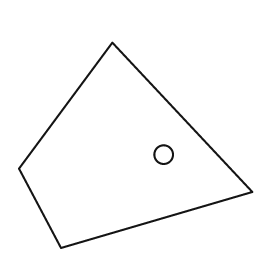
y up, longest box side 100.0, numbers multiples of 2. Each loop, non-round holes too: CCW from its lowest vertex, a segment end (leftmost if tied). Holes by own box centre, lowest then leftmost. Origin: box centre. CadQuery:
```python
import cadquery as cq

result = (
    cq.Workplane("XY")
    .moveTo(-32.0, -44.0)
    .lineTo(50.0, -20.0)
    .lineTo(-10.0, 44.0)
    .lineTo(-50.0, -10.0)
    .close()
    .moveTo(12.0, -4.0)
    .circle(4.0)
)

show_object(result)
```